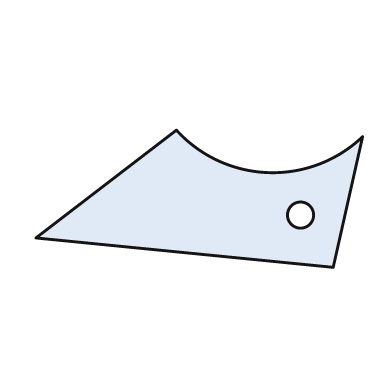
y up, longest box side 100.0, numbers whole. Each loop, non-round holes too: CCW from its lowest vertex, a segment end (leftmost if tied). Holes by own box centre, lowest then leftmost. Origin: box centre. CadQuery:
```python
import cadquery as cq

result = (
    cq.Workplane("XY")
    .moveTo(41.0, -21.0)
    .lineTo(50.0, 19.0)
    .threePointArc((21.0, 8.0), (-7.0, 21.0))
    .lineTo(-50.0, -12.0)
    .close()
    .moveTo(31.0, -5.0)
    .circle(4.0)
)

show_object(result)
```